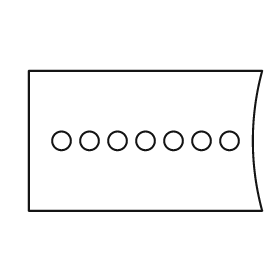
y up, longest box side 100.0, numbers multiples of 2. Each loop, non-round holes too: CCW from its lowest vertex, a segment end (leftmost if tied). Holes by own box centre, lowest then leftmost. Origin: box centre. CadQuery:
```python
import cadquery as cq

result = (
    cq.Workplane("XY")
    .moveTo(-50.0, -30.0)
    .lineTo(50.0, -30.0)
    .threePointArc((46.0, 0.0), (50.0, 30.0))
    .lineTo(-50.0, 30.0)
    .close()
    .moveTo(-36.0, 0.0)
    .circle(4.0)
    .moveTo(-24.0, 0.0)
    .circle(4.0)
    .moveTo(-12.0, 0.0)
    .circle(4.0)
    .moveTo(0.0, 0.0)
    .circle(4.0)
    .moveTo(12.0, 0.0)
    .circle(4.0)
    .moveTo(24.0, 0.0)
    .circle(4.0)
    .moveTo(36.0, 0.0)
    .circle(4.0)
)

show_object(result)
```